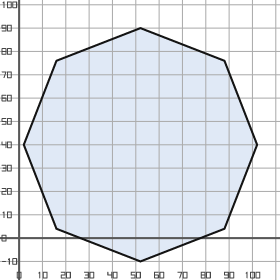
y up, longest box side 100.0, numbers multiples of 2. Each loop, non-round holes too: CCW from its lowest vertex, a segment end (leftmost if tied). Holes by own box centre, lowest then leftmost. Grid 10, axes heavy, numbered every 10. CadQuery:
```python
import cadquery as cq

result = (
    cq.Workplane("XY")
    .moveTo(52.0, -10.0)
    .lineTo(88.0, 4.0)
    .lineTo(102.0, 40.0)
    .lineTo(88.0, 76.0)
    .lineTo(52.0, 90.0)
    .lineTo(16.0, 76.0)
    .lineTo(2.0, 40.0)
    .lineTo(16.0, 4.0)
    .close()
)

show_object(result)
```